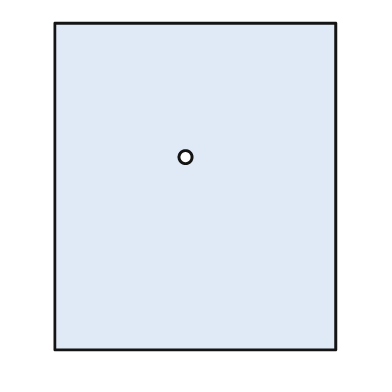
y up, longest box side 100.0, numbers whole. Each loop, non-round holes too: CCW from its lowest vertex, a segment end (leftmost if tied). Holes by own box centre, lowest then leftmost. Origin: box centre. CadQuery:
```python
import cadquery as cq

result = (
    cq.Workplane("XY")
    .moveTo(-43.0, -50.0)
    .lineTo(43.0, -50.0)
    .lineTo(43.0, 50.0)
    .lineTo(-43.0, 50.0)
    .close()
    .moveTo(-3.0, 9.0)
    .circle(2.0)
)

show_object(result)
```